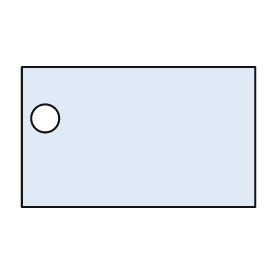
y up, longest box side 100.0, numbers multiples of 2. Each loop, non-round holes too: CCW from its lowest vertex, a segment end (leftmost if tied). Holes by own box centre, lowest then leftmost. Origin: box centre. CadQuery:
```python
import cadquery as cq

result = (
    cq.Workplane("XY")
    .moveTo(-50.0, -30.0)
    .lineTo(50.0, -30.0)
    .lineTo(50.0, 30.0)
    .lineTo(-50.0, 30.0)
    .close()
    .moveTo(-40.0, 8.0)
    .circle(6.0)
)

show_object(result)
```